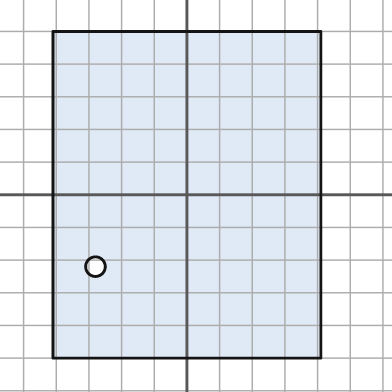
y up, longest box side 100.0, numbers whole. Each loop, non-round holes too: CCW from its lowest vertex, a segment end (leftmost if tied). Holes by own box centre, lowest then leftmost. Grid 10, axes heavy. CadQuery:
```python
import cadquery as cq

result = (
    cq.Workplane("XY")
    .moveTo(-41.0, -50.0)
    .lineTo(41.0, -50.0)
    .lineTo(41.0, 50.0)
    .lineTo(-41.0, 50.0)
    .close()
    .moveTo(-28.0, -22.0)
    .circle(3.0)
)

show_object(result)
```